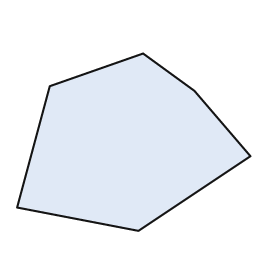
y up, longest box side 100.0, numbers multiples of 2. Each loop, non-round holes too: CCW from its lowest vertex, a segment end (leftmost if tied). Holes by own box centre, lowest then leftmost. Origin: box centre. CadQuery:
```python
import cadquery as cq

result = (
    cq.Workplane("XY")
    .moveTo(2.0, -38.0)
    .lineTo(50.0, -6.0)
    .lineTo(26.0, 22.0)
    .lineTo(4.0, 38.0)
    .lineTo(-36.0, 24.0)
    .lineTo(-50.0, -28.0)
    .close()
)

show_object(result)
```